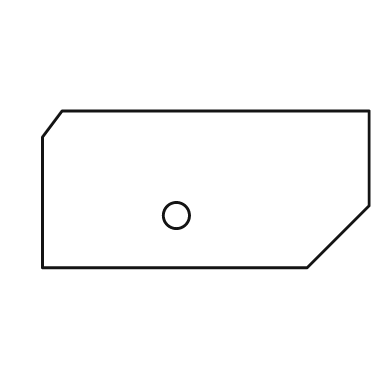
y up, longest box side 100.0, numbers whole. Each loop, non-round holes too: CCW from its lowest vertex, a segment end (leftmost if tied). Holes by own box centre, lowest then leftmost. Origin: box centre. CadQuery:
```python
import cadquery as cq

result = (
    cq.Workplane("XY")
    .moveTo(-50.0, -24.0)
    .lineTo(31.0, -24.0)
    .lineTo(50.0, -5.0)
    .lineTo(50.0, 24.0)
    .lineTo(-44.0, 24.0)
    .lineTo(-50.0, 16.0)
    .close()
    .moveTo(-9.0, -8.0)
    .circle(4.0)
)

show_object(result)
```